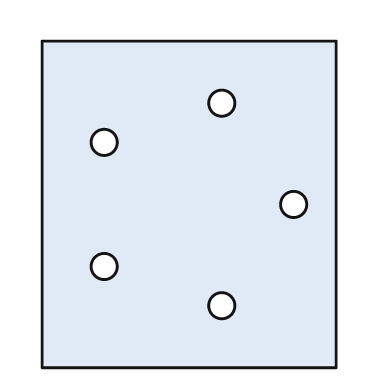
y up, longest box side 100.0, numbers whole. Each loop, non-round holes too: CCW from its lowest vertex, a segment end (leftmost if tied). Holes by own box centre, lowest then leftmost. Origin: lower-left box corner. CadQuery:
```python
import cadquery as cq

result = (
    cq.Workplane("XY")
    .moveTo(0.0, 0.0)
    .lineTo(90.0, 0.0)
    .lineTo(90.0, 100.0)
    .lineTo(0.0, 100.0)
    .close()
    .moveTo(55.0, 19.0)
    .circle(4.0)
    .moveTo(19.0, 31.0)
    .circle(4.0)
    .moveTo(77.0, 50.0)
    .circle(4.0)
    .moveTo(19.0, 69.0)
    .circle(4.0)
    .moveTo(55.0, 81.0)
    .circle(4.0)
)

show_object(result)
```